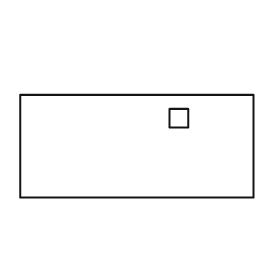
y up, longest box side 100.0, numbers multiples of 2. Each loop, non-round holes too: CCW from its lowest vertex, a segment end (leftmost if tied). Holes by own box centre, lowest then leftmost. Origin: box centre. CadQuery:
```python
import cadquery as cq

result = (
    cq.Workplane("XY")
    .moveTo(-50.0, -22.0)
    .lineTo(50.0, -22.0)
    .lineTo(50.0, 22.0)
    .lineTo(-50.0, 22.0)
    .close()
    .moveTo(14.0, 8.0)
    .lineTo(22.0, 8.0)
    .lineTo(22.0, 16.0)
    .lineTo(14.0, 16.0)
    .close()
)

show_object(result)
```